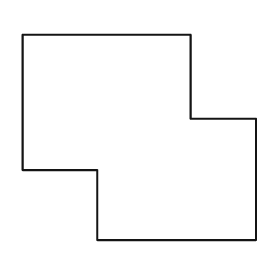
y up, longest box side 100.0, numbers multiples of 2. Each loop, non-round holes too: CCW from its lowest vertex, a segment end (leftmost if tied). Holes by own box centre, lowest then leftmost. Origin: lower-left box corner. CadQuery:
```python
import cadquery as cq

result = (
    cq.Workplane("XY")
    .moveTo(32.0, 0.0)
    .lineTo(100.0, 0.0)
    .lineTo(100.0, 52.0)
    .lineTo(72.0, 52.0)
    .lineTo(72.0, 88.0)
    .lineTo(0.0, 88.0)
    .lineTo(0.0, 30.0)
    .lineTo(32.0, 30.0)
    .close()
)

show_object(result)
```